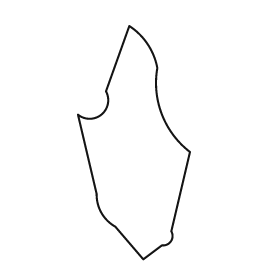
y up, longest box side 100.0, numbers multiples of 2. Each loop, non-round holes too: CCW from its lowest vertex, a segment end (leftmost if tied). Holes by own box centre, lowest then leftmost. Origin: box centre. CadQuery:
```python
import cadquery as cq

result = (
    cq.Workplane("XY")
    .moveTo(4.0, -50.0)
    .lineTo(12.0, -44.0)
    .threePointArc((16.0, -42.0), (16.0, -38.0))
    .lineTo(24.0, -4.0)
    .threePointArc((12.0, 12.0), (10.0, 32.0))
    .threePointArc((6.0, 42.0), (-2.0, 50.0))
    .lineTo(-12.0, 22.0)
    .threePointArc((-14.0, 12.0), (-24.0, 12.0))
    .lineTo(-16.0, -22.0)
    .threePointArc((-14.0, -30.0), (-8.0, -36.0))
    .close()
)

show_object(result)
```